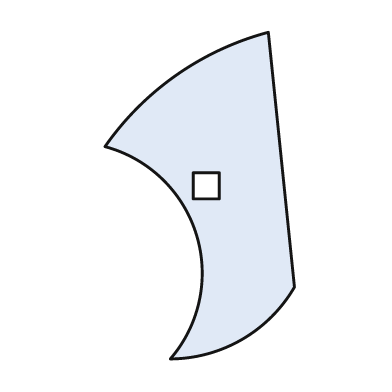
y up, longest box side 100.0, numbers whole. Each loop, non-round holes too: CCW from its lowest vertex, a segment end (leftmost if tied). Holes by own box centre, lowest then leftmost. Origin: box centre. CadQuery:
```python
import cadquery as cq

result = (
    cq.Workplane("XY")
    .moveTo(-9.0, -50.0)
    .threePointArc((13.0, -44.0), (29.0, -28.0))
    .lineTo(21.0, 50.0)
    .threePointArc((-7.0, 37.0), (-29.0, 15.0))
    .threePointArc((-1.0, -12.0), (-9.0, -50.0))
    .close()
    .moveTo(-2.0, -1.0)
    .lineTo(6.0, -1.0)
    .lineTo(6.0, 7.0)
    .lineTo(-2.0, 7.0)
    .close()
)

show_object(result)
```